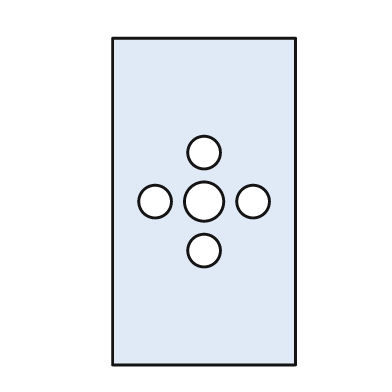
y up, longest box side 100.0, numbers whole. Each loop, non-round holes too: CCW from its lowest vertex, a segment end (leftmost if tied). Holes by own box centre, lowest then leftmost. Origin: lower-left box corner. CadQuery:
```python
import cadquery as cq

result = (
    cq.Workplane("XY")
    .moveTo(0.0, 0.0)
    .lineTo(56.0, 0.0)
    .lineTo(56.0, 100.0)
    .lineTo(0.0, 100.0)
    .close()
    .moveTo(28.0, 35.0)
    .circle(5.0)
    .moveTo(13.0, 50.0)
    .circle(5.0)
    .moveTo(28.0, 50.0)
    .circle(6.0)
    .moveTo(43.0, 50.0)
    .circle(5.0)
    .moveTo(28.0, 65.0)
    .circle(5.0)
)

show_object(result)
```